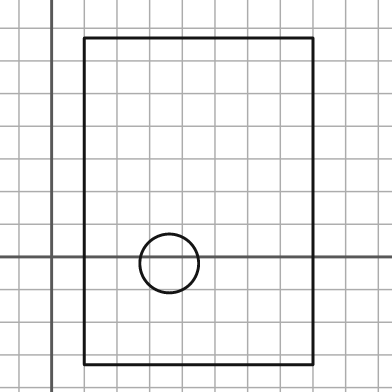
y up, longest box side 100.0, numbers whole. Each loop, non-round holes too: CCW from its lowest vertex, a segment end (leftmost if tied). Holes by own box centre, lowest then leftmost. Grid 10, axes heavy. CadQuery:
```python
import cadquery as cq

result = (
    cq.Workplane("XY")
    .moveTo(10.0, -33.0)
    .lineTo(80.0, -33.0)
    .lineTo(80.0, 67.0)
    .lineTo(10.0, 67.0)
    .close()
    .moveTo(36.0, -2.0)
    .circle(9.0)
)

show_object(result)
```